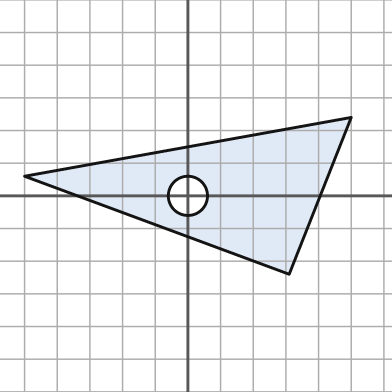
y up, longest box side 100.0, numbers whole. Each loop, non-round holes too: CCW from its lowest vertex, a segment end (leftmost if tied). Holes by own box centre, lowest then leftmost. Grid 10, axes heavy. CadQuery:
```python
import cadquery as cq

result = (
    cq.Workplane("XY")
    .moveTo(31.0, -24.0)
    .lineTo(50.0, 24.0)
    .lineTo(-50.0, 6.0)
    .close()
    .moveTo(0.0, 0.0)
    .circle(6.0)
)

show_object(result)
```